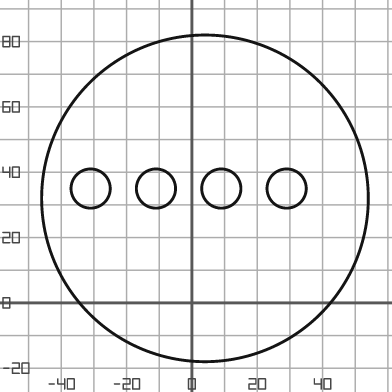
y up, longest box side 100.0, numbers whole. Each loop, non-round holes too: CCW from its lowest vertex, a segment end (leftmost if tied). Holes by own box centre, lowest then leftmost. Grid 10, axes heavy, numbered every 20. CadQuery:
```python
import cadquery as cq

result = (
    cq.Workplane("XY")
    .moveTo(4.0, 32.0)
    .circle(50.0)
    .moveTo(-31.0, 35.0)
    .circle(6.0)
    .moveTo(-11.0, 35.0)
    .circle(6.0)
    .moveTo(9.0, 35.0)
    .circle(6.0)
    .moveTo(29.0, 35.0)
    .circle(6.0)
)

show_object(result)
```